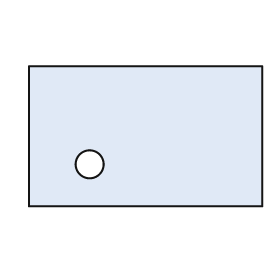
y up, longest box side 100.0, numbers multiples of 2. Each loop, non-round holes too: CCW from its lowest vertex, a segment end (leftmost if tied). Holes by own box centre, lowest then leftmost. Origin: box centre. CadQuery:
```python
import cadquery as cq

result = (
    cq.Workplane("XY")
    .moveTo(-50.0, -30.0)
    .lineTo(50.0, -30.0)
    .lineTo(50.0, 30.0)
    .lineTo(-50.0, 30.0)
    .close()
    .moveTo(-24.0, -12.0)
    .circle(6.0)
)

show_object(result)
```